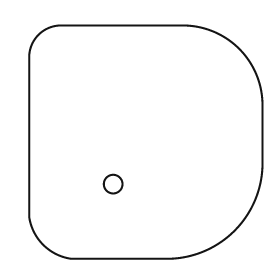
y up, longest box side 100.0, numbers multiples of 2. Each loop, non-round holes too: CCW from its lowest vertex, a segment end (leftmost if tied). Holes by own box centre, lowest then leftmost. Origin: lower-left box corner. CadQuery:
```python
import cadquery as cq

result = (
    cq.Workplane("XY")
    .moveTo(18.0, 0.0)
    .lineTo(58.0, 0.0)
    .threePointArc((88.0, 12.0), (100.0, 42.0))
    .lineTo(100.0, 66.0)
    .threePointArc((90.0, 90.0), (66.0, 100.0))
    .lineTo(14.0, 100.0)
    .threePointArc((4.0, 96.0), (0.0, 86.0))
    .lineTo(0.0, 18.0)
    .threePointArc((6.0, 6.0), (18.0, 0.0))
    .close()
    .moveTo(36.0, 32.0)
    .circle(4.0)
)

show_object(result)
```